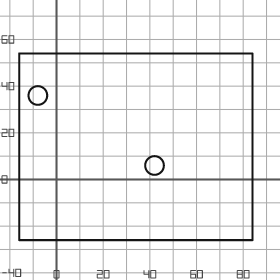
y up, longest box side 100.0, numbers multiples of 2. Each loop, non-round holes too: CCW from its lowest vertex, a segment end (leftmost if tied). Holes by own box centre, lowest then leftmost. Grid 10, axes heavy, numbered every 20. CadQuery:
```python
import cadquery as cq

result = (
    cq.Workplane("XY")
    .moveTo(-16.0, -26.0)
    .lineTo(84.0, -26.0)
    .lineTo(84.0, 54.0)
    .lineTo(-16.0, 54.0)
    .close()
    .moveTo(42.0, 6.0)
    .circle(4.0)
    .moveTo(-8.0, 36.0)
    .circle(4.0)
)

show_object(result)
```